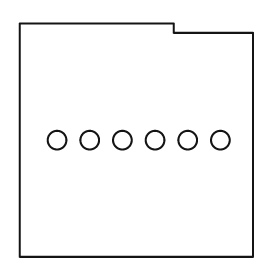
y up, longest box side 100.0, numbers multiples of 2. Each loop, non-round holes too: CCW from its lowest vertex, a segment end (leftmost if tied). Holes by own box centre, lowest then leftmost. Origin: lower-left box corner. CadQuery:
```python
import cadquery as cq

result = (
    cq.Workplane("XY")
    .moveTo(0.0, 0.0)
    .lineTo(100.0, 0.0)
    .lineTo(100.0, 96.0)
    .lineTo(66.0, 96.0)
    .lineTo(66.0, 100.0)
    .lineTo(0.0, 100.0)
    .close()
    .moveTo(16.0, 50.0)
    .circle(4.0)
    .moveTo(30.0, 50.0)
    .circle(4.0)
    .moveTo(44.0, 50.0)
    .circle(4.0)
    .moveTo(58.0, 50.0)
    .circle(4.0)
    .moveTo(72.0, 50.0)
    .circle(4.0)
    .moveTo(86.0, 50.0)
    .circle(4.0)
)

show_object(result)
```